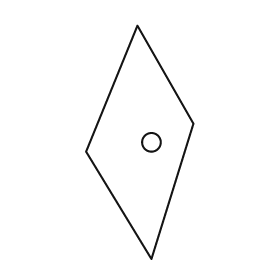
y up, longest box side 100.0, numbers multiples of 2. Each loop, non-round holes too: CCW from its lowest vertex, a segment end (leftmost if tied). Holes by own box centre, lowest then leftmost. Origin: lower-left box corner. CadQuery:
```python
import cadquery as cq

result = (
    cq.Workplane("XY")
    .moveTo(28.0, 0.0)
    .lineTo(46.0, 58.0)
    .lineTo(22.0, 100.0)
    .lineTo(0.0, 46.0)
    .close()
    .moveTo(28.0, 50.0)
    .circle(4.0)
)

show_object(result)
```